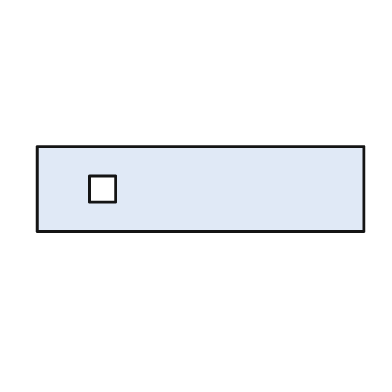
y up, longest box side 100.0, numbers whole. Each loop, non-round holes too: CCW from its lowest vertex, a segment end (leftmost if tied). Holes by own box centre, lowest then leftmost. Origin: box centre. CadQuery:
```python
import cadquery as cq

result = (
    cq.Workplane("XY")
    .moveTo(-50.0, -13.0)
    .lineTo(50.0, -13.0)
    .lineTo(50.0, 13.0)
    .lineTo(-50.0, 13.0)
    .close()
    .moveTo(-34.0, -4.0)
    .lineTo(-26.0, -4.0)
    .lineTo(-26.0, 4.0)
    .lineTo(-34.0, 4.0)
    .close()
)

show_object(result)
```